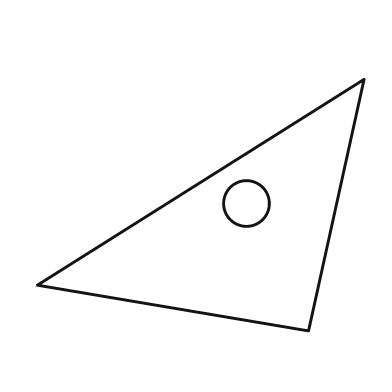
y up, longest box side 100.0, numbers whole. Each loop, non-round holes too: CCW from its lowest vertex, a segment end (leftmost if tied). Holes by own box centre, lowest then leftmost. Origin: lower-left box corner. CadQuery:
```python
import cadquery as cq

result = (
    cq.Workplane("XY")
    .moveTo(83.0, 0.0)
    .lineTo(100.0, 77.0)
    .lineTo(0.0, 14.0)
    .close()
    .moveTo(64.0, 39.0)
    .circle(7.0)
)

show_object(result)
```